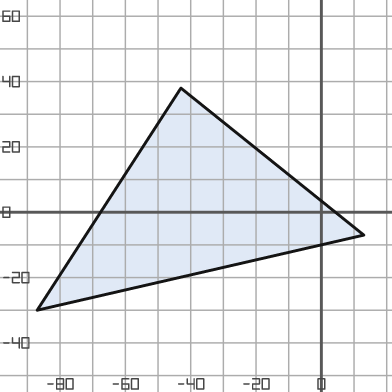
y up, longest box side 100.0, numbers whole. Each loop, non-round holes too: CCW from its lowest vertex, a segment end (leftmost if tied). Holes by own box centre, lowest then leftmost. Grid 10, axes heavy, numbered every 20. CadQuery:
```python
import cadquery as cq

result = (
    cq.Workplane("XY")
    .moveTo(-87.0, -30.0)
    .lineTo(13.0, -7.0)
    .lineTo(-43.0, 38.0)
    .close()
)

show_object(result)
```